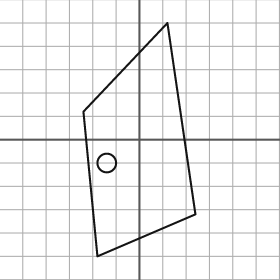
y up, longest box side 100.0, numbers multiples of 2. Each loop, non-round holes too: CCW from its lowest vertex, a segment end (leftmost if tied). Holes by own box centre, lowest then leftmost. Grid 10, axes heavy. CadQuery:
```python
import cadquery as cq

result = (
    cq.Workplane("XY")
    .moveTo(-18.0, -50.0)
    .lineTo(24.0, -32.0)
    .lineTo(12.0, 50.0)
    .lineTo(-24.0, 12.0)
    .close()
    .moveTo(-14.0, -10.0)
    .circle(4.0)
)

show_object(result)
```